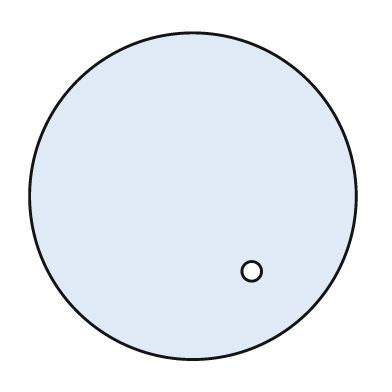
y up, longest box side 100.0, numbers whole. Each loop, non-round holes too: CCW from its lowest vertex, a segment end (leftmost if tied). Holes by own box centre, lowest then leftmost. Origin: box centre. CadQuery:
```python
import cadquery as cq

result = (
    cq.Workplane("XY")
    .moveTo(0.0, 0.0)
    .circle(50.0)
    .moveTo(18.0, -23.0)
    .circle(3.0)
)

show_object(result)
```